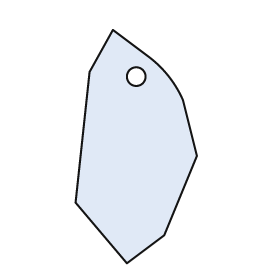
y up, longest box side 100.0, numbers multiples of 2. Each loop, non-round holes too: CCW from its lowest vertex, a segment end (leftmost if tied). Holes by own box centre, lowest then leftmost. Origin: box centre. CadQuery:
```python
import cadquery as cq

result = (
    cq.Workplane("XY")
    .moveTo(-4.0, -50.0)
    .lineTo(12.0, -38.0)
    .lineTo(26.0, -4.0)
    .lineTo(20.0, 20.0)
    .threePointArc((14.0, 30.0), (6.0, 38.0))
    .lineTo(-10.0, 50.0)
    .lineTo(-20.0, 32.0)
    .lineTo(-26.0, -24.0)
    .close()
    .moveTo(0.0, 30.0)
    .circle(4.0)
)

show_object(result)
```